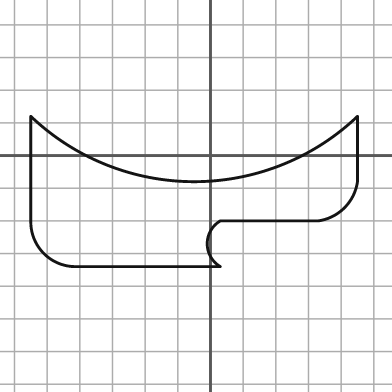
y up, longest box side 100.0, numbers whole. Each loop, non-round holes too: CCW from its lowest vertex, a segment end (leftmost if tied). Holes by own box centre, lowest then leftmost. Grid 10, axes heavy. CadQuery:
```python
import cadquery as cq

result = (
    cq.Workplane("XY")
    .moveTo(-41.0, -34.0)
    .lineTo(3.0, -34.0)
    .threePointArc((-1.0, -27.0), (3.0, -20.0))
    .lineTo(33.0, -20.0)
    .threePointArc((41.0, -16.0), (45.0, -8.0))
    .lineTo(45.0, 12.0)
    .threePointArc((-5.0, -8.0), (-55.0, 12.0))
    .lineTo(-55.0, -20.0)
    .threePointArc((-51.0, -30.0), (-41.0, -34.0))
    .close()
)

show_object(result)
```